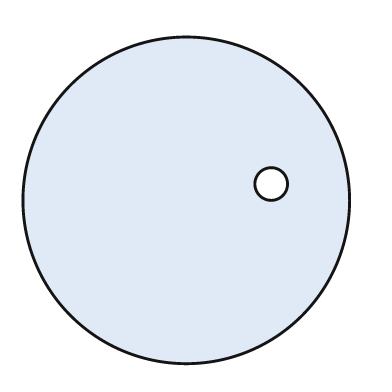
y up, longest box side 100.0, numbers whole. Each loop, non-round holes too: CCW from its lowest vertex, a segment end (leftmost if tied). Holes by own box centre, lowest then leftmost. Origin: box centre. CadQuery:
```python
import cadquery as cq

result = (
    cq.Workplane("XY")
    .moveTo(0.0, 0.0)
    .circle(50.0)
    .moveTo(26.0, 5.0)
    .circle(5.0)
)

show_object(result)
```